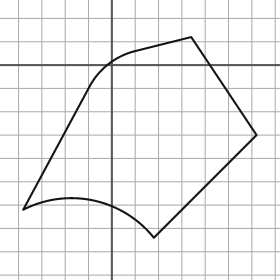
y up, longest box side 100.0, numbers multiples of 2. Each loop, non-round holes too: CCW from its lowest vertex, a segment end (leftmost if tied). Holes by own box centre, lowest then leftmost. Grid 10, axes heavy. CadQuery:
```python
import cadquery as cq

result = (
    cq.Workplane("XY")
    .moveTo(18.0, -74.0)
    .lineTo(62.0, -30.0)
    .lineTo(34.0, 12.0)
    .lineTo(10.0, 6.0)
    .threePointArc((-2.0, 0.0), (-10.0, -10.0))
    .lineTo(-38.0, -62.0)
    .threePointArc((-8.0, -58.0), (18.0, -74.0))
    .close()
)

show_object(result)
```